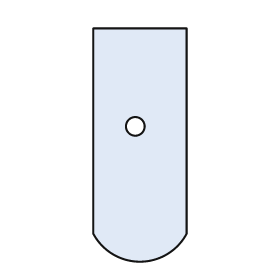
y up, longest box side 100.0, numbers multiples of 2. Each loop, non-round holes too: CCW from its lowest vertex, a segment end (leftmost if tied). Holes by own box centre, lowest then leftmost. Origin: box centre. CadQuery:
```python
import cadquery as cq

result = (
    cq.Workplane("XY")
    .moveTo(-20.0, -38.0)
    .threePointArc((0.0, -50.0), (20.0, -38.0))
    .lineTo(20.0, 50.0)
    .lineTo(-20.0, 50.0)
    .close()
    .moveTo(-2.0, 8.0)
    .circle(4.0)
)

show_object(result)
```